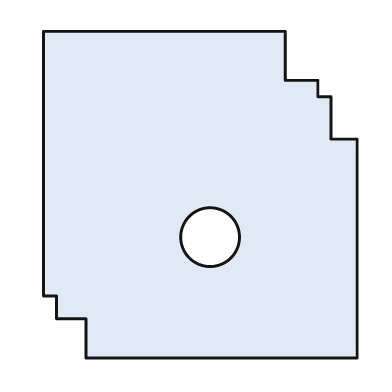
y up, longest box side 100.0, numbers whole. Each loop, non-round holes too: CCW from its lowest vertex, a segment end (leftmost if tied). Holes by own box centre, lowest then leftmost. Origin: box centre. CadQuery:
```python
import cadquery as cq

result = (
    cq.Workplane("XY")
    .moveTo(-35.0, -50.0)
    .lineTo(48.0, -50.0)
    .lineTo(48.0, 17.0)
    .lineTo(40.0, 17.0)
    .lineTo(40.0, 30.0)
    .lineTo(36.0, 30.0)
    .lineTo(36.0, 35.0)
    .lineTo(26.0, 35.0)
    .lineTo(26.0, 50.0)
    .lineTo(-48.0, 50.0)
    .lineTo(-48.0, -31.0)
    .lineTo(-44.0, -31.0)
    .lineTo(-44.0, -38.0)
    .lineTo(-35.0, -38.0)
    .close()
    .moveTo(3.0, -13.0)
    .circle(9.0)
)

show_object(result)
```